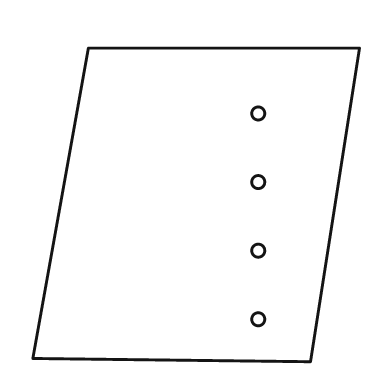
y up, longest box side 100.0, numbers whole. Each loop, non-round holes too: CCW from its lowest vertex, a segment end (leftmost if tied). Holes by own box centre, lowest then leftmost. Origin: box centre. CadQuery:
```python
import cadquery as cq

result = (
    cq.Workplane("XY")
    .moveTo(35.0, -48.0)
    .lineTo(50.0, 48.0)
    .lineTo(-33.0, 48.0)
    .lineTo(-50.0, -47.0)
    .close()
    .moveTo(19.0, -35.0)
    .circle(2.0)
    .moveTo(19.0, -14.0)
    .circle(2.0)
    .moveTo(19.0, 7.0)
    .circle(2.0)
    .moveTo(19.0, 28.0)
    .circle(2.0)
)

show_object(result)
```